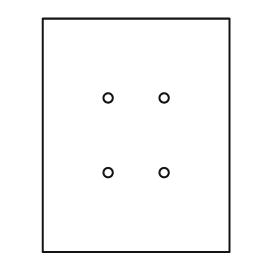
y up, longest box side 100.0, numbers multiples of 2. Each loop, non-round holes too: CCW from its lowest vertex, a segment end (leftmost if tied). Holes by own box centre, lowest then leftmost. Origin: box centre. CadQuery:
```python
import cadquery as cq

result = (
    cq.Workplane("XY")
    .moveTo(-40.0, -50.0)
    .lineTo(40.0, -50.0)
    .lineTo(40.0, 50.0)
    .lineTo(-40.0, 50.0)
    .close()
    .moveTo(-12.0, -16.0)
    .circle(2.0)
    .moveTo(12.0, -16.0)
    .circle(2.0)
    .moveTo(-12.0, 16.0)
    .circle(2.0)
    .moveTo(12.0, 16.0)
    .circle(2.0)
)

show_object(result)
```